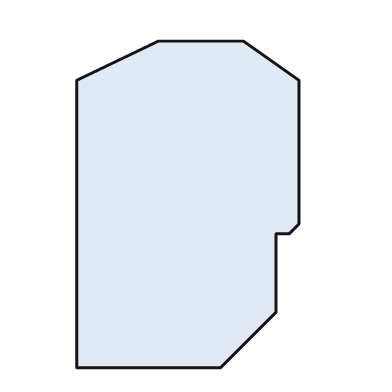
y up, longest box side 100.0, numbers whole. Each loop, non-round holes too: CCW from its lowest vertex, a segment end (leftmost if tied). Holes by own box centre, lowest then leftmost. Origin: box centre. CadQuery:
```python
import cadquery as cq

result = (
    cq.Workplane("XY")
    .moveTo(-34.0, -50.0)
    .lineTo(10.0, -50.0)
    .lineTo(27.0, -33.0)
    .lineTo(27.0, -9.0)
    .lineTo(31.0, -9.0)
    .lineTo(34.0, -6.0)
    .lineTo(34.0, 38.0)
    .lineTo(17.0, 50.0)
    .lineTo(-9.0, 50.0)
    .lineTo(-34.0, 38.0)
    .close()
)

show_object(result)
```